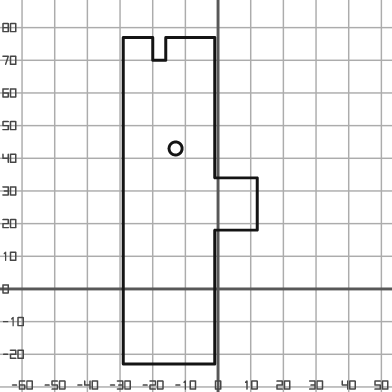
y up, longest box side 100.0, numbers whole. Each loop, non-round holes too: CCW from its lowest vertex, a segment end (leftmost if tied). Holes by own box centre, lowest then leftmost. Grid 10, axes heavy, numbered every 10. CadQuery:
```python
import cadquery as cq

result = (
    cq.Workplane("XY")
    .moveTo(-29.0, -23.0)
    .lineTo(-1.0, -23.0)
    .lineTo(-1.0, 18.0)
    .lineTo(12.0, 18.0)
    .lineTo(12.0, 34.0)
    .lineTo(-1.0, 34.0)
    .lineTo(-1.0, 77.0)
    .lineTo(-16.0, 77.0)
    .lineTo(-16.0, 70.0)
    .lineTo(-20.0, 70.0)
    .lineTo(-20.0, 77.0)
    .lineTo(-29.0, 77.0)
    .close()
    .moveTo(-13.0, 43.0)
    .circle(2.0)
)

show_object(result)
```